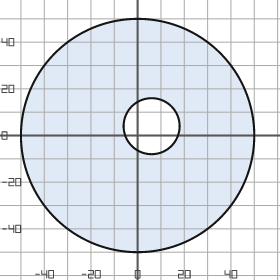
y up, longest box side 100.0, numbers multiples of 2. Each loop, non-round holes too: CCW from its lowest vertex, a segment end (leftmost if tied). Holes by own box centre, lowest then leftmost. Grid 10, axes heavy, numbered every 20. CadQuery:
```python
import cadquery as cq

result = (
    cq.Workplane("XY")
    .moveTo(0.0, 0.0)
    .circle(50.0)
    .moveTo(6.0, 4.0)
    .circle(12.0)
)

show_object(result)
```